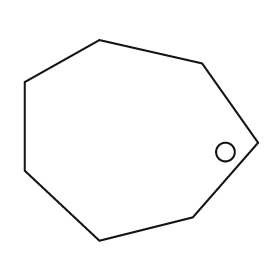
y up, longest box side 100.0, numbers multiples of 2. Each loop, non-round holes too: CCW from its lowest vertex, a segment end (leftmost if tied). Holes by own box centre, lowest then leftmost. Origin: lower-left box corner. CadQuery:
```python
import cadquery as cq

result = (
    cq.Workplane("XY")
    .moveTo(32.0, 0.0)
    .lineTo(72.0, 10.0)
    .lineTo(100.0, 42.0)
    .lineTo(76.0, 76.0)
    .lineTo(32.0, 86.0)
    .lineTo(0.0, 68.0)
    .lineTo(0.0, 30.0)
    .close()
    .moveTo(86.0, 38.0)
    .circle(4.0)
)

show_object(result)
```